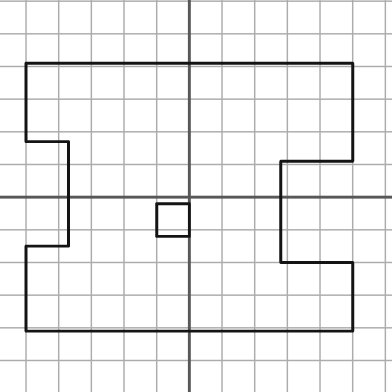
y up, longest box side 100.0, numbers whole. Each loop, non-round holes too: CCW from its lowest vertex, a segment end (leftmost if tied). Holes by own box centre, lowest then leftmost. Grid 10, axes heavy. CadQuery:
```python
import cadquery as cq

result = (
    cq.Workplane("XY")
    .moveTo(-50.0, -41.0)
    .lineTo(50.0, -41.0)
    .lineTo(50.0, -20.0)
    .lineTo(28.0, -20.0)
    .lineTo(28.0, 11.0)
    .lineTo(50.0, 11.0)
    .lineTo(50.0, 41.0)
    .lineTo(-50.0, 41.0)
    .lineTo(-50.0, 17.0)
    .lineTo(-37.0, 17.0)
    .lineTo(-37.0, -15.0)
    .lineTo(-50.0, -15.0)
    .close()
    .moveTo(-10.0, -12.0)
    .lineTo(0.0, -12.0)
    .lineTo(0.0, -2.0)
    .lineTo(-10.0, -2.0)
    .close()
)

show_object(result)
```